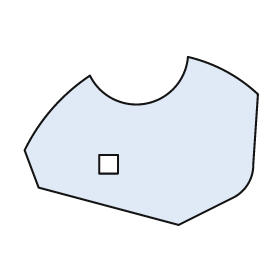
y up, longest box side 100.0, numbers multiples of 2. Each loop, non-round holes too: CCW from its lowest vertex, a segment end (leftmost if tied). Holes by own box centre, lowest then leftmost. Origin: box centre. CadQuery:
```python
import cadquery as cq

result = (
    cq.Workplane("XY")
    .moveTo(16.0, -36.0)
    .lineTo(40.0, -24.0)
    .threePointArc((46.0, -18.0), (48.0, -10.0))
    .lineTo(50.0, 20.0)
    .threePointArc((36.0, 30.0), (20.0, 36.0))
    .threePointArc((2.0, 16.0), (-22.0, 28.0))
    .threePointArc((-38.0, 14.0), (-50.0, -4.0))
    .lineTo(-44.0, -20.0)
    .close()
    .moveTo(-18.0, -14.0)
    .lineTo(-10.0, -14.0)
    .lineTo(-10.0, -6.0)
    .lineTo(-18.0, -6.0)
    .close()
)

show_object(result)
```